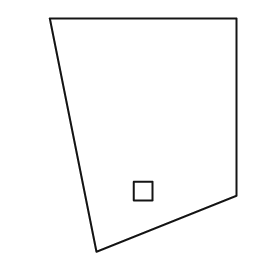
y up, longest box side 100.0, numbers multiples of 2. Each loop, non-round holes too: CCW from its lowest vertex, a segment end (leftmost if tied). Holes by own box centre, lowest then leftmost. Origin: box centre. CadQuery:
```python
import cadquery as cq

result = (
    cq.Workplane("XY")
    .moveTo(-20.0, -50.0)
    .lineTo(40.0, -26.0)
    .lineTo(40.0, 50.0)
    .lineTo(-40.0, 50.0)
    .close()
    .moveTo(-4.0, -28.0)
    .lineTo(4.0, -28.0)
    .lineTo(4.0, -20.0)
    .lineTo(-4.0, -20.0)
    .close()
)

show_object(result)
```